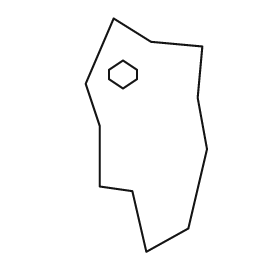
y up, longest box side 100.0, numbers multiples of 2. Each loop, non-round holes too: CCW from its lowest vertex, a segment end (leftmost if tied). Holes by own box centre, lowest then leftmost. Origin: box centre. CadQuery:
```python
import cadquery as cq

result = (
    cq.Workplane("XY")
    .moveTo(0.0, -50.0)
    .lineTo(18.0, -40.0)
    .lineTo(26.0, -6.0)
    .lineTo(22.0, 16.0)
    .lineTo(24.0, 38.0)
    .lineTo(2.0, 40.0)
    .lineTo(-14.0, 50.0)
    .lineTo(-26.0, 22.0)
    .lineTo(-20.0, 4.0)
    .lineTo(-20.0, -22.0)
    .lineTo(-6.0, -24.0)
    .close()
    .moveTo(-10.0, 20.0)
    .lineTo(-4.0, 24.0)
    .lineTo(-4.0, 28.0)
    .lineTo(-10.0, 32.0)
    .lineTo(-16.0, 28.0)
    .lineTo(-16.0, 24.0)
    .close()
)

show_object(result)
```